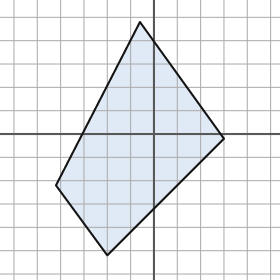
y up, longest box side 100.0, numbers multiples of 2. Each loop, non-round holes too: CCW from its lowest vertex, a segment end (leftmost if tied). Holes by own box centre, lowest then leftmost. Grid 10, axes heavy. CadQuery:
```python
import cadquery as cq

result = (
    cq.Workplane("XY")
    .moveTo(-20.0, -52.0)
    .lineTo(30.0, -2.0)
    .lineTo(-6.0, 48.0)
    .lineTo(-42.0, -22.0)
    .close()
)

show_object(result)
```